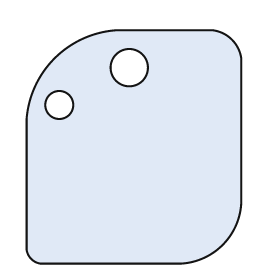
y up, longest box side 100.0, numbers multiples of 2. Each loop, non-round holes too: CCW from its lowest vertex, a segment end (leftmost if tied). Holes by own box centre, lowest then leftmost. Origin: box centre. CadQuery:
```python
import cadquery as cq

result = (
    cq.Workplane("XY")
    .moveTo(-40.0, -50.0)
    .lineTo(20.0, -50.0)
    .threePointArc((38.0, -42.0), (46.0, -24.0))
    .lineTo(46.0, 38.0)
    .threePointArc((42.0, 46.0), (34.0, 50.0))
    .lineTo(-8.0, 50.0)
    .threePointArc((-34.0, 38.0), (-46.0, 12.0))
    .lineTo(-46.0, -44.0)
    .threePointArc((-44.0, -48.0), (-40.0, -50.0))
    .close()
    .moveTo(-32.0, 18.0)
    .circle(6.0)
    .moveTo(-2.0, 34.0)
    .circle(8.0)
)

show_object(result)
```